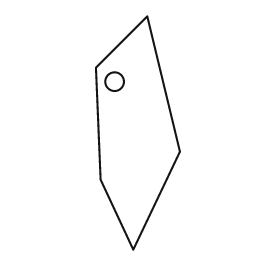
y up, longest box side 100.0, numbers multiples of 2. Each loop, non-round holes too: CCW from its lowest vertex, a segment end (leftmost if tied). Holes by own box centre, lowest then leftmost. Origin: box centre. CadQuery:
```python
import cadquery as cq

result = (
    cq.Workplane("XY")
    .moveTo(-2.0, -50.0)
    .lineTo(18.0, -8.0)
    .lineTo(4.0, 50.0)
    .lineTo(-18.0, 28.0)
    .lineTo(-16.0, -20.0)
    .close()
    .moveTo(-10.0, 22.0)
    .circle(4.0)
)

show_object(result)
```